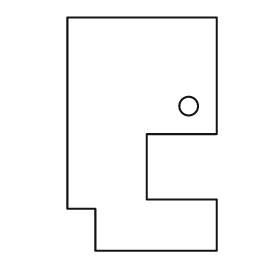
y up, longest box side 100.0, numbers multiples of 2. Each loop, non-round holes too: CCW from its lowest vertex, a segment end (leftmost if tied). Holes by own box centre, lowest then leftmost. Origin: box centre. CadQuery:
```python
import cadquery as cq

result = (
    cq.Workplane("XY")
    .moveTo(-20.0, -50.0)
    .lineTo(32.0, -50.0)
    .lineTo(32.0, -28.0)
    .lineTo(2.0, -28.0)
    .lineTo(2.0, 0.0)
    .lineTo(32.0, 0.0)
    .lineTo(32.0, 50.0)
    .lineTo(-32.0, 50.0)
    .lineTo(-32.0, -32.0)
    .lineTo(-20.0, -32.0)
    .close()
    .moveTo(20.0, 12.0)
    .circle(4.0)
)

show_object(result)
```